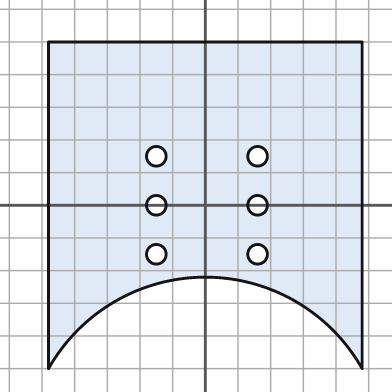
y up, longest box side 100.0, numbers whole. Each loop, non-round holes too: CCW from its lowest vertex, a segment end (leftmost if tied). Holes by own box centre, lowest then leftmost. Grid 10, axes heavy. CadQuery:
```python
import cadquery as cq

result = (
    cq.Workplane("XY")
    .moveTo(-48.0, -50.0)
    .threePointArc((0.0, -22.0), (48.0, -50.0))
    .lineTo(48.0, 50.0)
    .lineTo(-48.0, 50.0)
    .close()
    .moveTo(-15.0, -15.0)
    .circle(3.0)
    .moveTo(16.0, -15.0)
    .circle(3.0)
    .moveTo(-15.0, 0.0)
    .circle(3.0)
    .moveTo(16.0, 0.0)
    .circle(3.0)
    .moveTo(-15.0, 15.0)
    .circle(3.0)
    .moveTo(16.0, 15.0)
    .circle(3.0)
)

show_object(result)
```